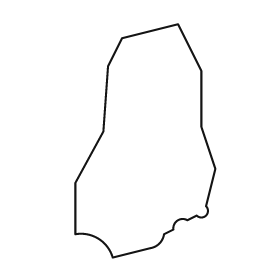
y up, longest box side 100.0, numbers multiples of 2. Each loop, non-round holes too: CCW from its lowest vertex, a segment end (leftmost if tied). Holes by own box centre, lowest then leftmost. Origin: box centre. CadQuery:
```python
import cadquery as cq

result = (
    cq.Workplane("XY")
    .moveTo(-14.0, -50.0)
    .lineTo(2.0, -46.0)
    .threePointArc((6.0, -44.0), (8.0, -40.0))
    .lineTo(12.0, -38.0)
    .threePointArc((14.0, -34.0), (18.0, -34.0))
    .lineTo(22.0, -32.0)
    .threePointArc((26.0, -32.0), (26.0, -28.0))
    .lineTo(30.0, -12.0)
    .lineTo(24.0, 6.0)
    .lineTo(24.0, 30.0)
    .lineTo(14.0, 50.0)
    .lineTo(-10.0, 44.0)
    .lineTo(-16.0, 32.0)
    .lineTo(-18.0, 4.0)
    .lineTo(-30.0, -18.0)
    .lineTo(-30.0, -40.0)
    .threePointArc((-20.0, -42.0), (-14.0, -50.0))
    .close()
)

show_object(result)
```